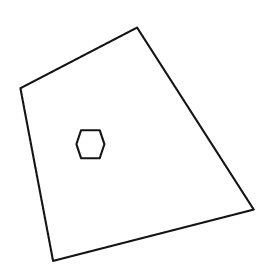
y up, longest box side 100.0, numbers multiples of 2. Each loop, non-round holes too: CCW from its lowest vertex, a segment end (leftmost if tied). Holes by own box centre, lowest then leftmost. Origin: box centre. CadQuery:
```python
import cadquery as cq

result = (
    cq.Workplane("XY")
    .moveTo(-36.0, -50.0)
    .lineTo(50.0, -28.0)
    .lineTo(0.0, 50.0)
    .lineTo(-50.0, 24.0)
    .close()
    .moveTo(-24.0, -6.0)
    .lineTo(-16.0, -6.0)
    .lineTo(-14.0, 0.0)
    .lineTo(-16.0, 6.0)
    .lineTo(-24.0, 6.0)
    .lineTo(-26.0, 0.0)
    .close()
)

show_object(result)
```